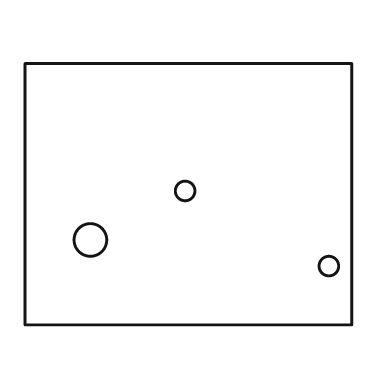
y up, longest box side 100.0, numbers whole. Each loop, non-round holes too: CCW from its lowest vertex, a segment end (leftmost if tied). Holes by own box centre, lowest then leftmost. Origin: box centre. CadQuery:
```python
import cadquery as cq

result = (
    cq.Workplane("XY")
    .moveTo(-50.0, -40.0)
    .lineTo(50.0, -40.0)
    .lineTo(50.0, 40.0)
    .lineTo(-50.0, 40.0)
    .close()
    .moveTo(43.0, -22.0)
    .circle(3.0)
    .moveTo(-30.0, -14.0)
    .circle(5.0)
    .moveTo(-1.0, 1.0)
    .circle(3.0)
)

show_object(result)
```